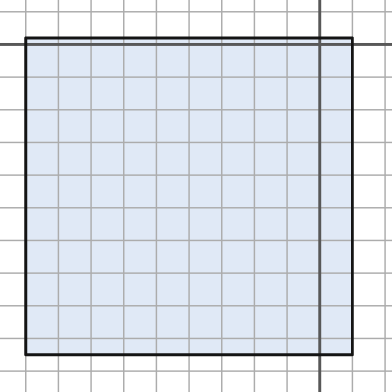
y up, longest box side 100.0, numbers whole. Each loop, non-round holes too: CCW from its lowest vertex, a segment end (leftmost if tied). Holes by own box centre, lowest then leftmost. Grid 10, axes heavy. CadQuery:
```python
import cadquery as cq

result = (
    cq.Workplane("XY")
    .moveTo(-90.0, -95.0)
    .lineTo(10.0, -95.0)
    .lineTo(10.0, 2.0)
    .lineTo(-90.0, 2.0)
    .close()
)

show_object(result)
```